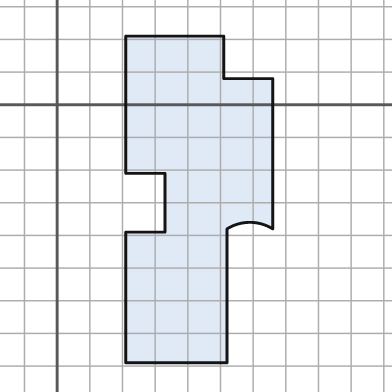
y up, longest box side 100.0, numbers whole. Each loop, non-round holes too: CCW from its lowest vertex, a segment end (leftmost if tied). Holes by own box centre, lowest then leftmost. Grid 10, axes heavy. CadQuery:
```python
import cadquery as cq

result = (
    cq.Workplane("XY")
    .moveTo(21.0, -79.0)
    .lineTo(52.0, -79.0)
    .lineTo(52.0, -38.0)
    .threePointArc((59.0, -36.0), (66.0, -38.0))
    .lineTo(66.0, 8.0)
    .lineTo(51.0, 8.0)
    .lineTo(51.0, 21.0)
    .lineTo(21.0, 21.0)
    .lineTo(21.0, -21.0)
    .lineTo(33.0, -21.0)
    .lineTo(33.0, -39.0)
    .lineTo(21.0, -39.0)
    .close()
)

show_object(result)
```